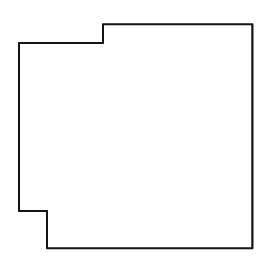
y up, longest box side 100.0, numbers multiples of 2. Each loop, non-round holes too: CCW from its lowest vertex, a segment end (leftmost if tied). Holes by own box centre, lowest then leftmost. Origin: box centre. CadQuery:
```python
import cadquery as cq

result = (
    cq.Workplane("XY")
    .moveTo(-38.0, -48.0)
    .lineTo(50.0, -48.0)
    .lineTo(50.0, 48.0)
    .lineTo(-14.0, 48.0)
    .lineTo(-14.0, 40.0)
    .lineTo(-50.0, 40.0)
    .lineTo(-50.0, -32.0)
    .lineTo(-38.0, -32.0)
    .close()
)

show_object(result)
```